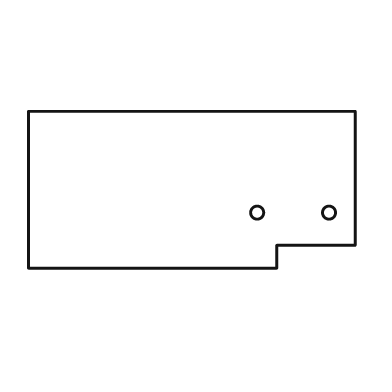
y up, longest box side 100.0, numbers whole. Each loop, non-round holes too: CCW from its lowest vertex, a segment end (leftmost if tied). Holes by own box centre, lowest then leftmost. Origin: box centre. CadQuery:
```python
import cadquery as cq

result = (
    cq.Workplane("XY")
    .moveTo(-50.0, -24.0)
    .lineTo(26.0, -24.0)
    .lineTo(26.0, -17.0)
    .lineTo(50.0, -17.0)
    .lineTo(50.0, 24.0)
    .lineTo(-50.0, 24.0)
    .close()
    .moveTo(20.0, -7.0)
    .circle(2.0)
    .moveTo(42.0, -7.0)
    .circle(2.0)
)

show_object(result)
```